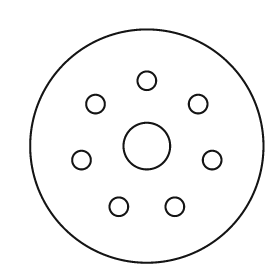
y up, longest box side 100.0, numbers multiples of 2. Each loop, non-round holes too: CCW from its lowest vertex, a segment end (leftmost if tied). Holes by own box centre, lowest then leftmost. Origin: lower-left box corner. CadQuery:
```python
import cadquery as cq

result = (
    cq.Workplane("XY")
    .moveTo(50.0, 50.0)
    .circle(50.0)
    .moveTo(38.0, 24.0)
    .circle(4.0)
    .moveTo(62.0, 24.0)
    .circle(4.0)
    .moveTo(22.0, 44.0)
    .circle(4.0)
    .moveTo(78.0, 44.0)
    .circle(4.0)
    .moveTo(50.0, 50.0)
    .circle(10.0)
    .moveTo(28.0, 68.0)
    .circle(4.0)
    .moveTo(72.0, 68.0)
    .circle(4.0)
    .moveTo(50.0, 78.0)
    .circle(4.0)
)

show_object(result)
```